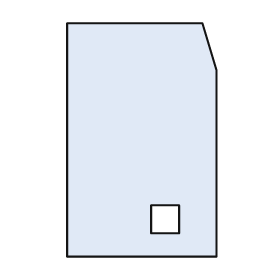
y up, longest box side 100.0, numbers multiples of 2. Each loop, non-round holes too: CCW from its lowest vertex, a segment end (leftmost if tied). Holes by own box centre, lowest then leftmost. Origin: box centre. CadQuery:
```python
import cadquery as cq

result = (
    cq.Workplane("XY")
    .moveTo(-32.0, -50.0)
    .lineTo(32.0, -50.0)
    .lineTo(32.0, 30.0)
    .lineTo(26.0, 50.0)
    .lineTo(-32.0, 50.0)
    .close()
    .moveTo(4.0, -40.0)
    .lineTo(16.0, -40.0)
    .lineTo(16.0, -28.0)
    .lineTo(4.0, -28.0)
    .close()
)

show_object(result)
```